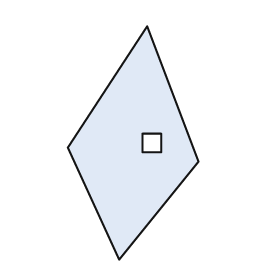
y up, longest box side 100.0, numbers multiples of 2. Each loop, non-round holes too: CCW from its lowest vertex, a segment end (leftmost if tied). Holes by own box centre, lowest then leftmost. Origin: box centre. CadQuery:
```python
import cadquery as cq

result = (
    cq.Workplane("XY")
    .moveTo(-6.0, -50.0)
    .lineTo(28.0, -8.0)
    .lineTo(6.0, 50.0)
    .lineTo(-28.0, -2.0)
    .close()
    .moveTo(4.0, -4.0)
    .lineTo(12.0, -4.0)
    .lineTo(12.0, 4.0)
    .lineTo(4.0, 4.0)
    .close()
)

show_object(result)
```